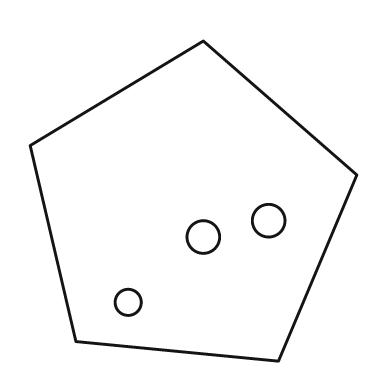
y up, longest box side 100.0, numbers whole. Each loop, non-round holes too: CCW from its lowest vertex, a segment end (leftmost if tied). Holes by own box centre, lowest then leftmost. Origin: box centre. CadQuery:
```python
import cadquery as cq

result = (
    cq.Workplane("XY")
    .moveTo(26.0, -49.0)
    .lineTo(50.0, 8.0)
    .lineTo(3.0, 49.0)
    .lineTo(-50.0, 17.0)
    .lineTo(-36.0, -43.0)
    .close()
    .moveTo(-20.0, -31.0)
    .circle(4.0)
    .moveTo(3.0, -11.0)
    .circle(5.0)
    .moveTo(23.0, -6.0)
    .circle(5.0)
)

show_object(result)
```